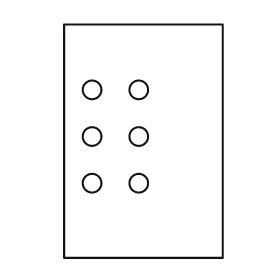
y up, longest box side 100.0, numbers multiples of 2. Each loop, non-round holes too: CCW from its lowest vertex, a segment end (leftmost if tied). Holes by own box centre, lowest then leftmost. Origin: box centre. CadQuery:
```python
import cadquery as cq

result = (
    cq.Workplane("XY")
    .moveTo(-34.0, -50.0)
    .lineTo(34.0, -50.0)
    .lineTo(34.0, 50.0)
    .lineTo(-34.0, 50.0)
    .close()
    .moveTo(-22.0, -18.0)
    .circle(4.0)
    .moveTo(-2.0, -18.0)
    .circle(4.0)
    .moveTo(-22.0, 2.0)
    .circle(4.0)
    .moveTo(-2.0, 2.0)
    .circle(4.0)
    .moveTo(-22.0, 22.0)
    .circle(4.0)
    .moveTo(-2.0, 22.0)
    .circle(4.0)
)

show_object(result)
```